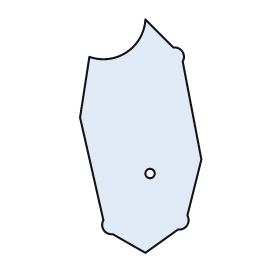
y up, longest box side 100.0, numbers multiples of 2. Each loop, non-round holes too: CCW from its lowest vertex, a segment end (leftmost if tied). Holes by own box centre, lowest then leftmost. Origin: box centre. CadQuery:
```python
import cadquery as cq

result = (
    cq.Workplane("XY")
    .moveTo(2.0, -50.0)
    .lineTo(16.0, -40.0)
    .threePointArc((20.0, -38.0), (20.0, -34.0))
    .lineTo(26.0, -10.0)
    .lineTo(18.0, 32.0)
    .threePointArc((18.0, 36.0), (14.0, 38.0))
    .lineTo(2.0, 50.0)
    .threePointArc((-6.0, 36.0), (-22.0, 34.0))
    .lineTo(-26.0, 8.0)
    .lineTo(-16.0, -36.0)
    .threePointArc((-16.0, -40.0), (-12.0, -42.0))
    .close()
    .moveTo(4.0, -16.0)
    .circle(2.0)
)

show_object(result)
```